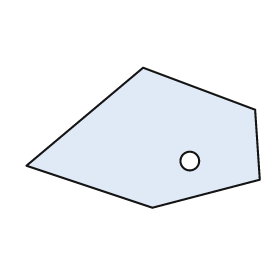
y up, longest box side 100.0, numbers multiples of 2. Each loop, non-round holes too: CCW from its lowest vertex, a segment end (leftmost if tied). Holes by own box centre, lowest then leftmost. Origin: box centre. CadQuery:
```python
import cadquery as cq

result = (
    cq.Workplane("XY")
    .moveTo(4.0, -30.0)
    .lineTo(50.0, -18.0)
    .lineTo(48.0, 12.0)
    .lineTo(0.0, 30.0)
    .lineTo(-50.0, -12.0)
    .close()
    .moveTo(20.0, -10.0)
    .circle(4.0)
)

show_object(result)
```